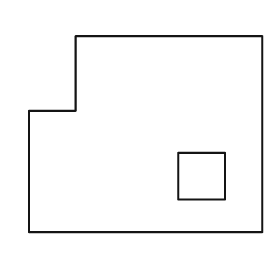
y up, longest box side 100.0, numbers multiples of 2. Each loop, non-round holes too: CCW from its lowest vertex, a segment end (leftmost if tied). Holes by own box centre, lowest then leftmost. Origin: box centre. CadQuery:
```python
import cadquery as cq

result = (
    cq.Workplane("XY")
    .moveTo(-50.0, -42.0)
    .lineTo(50.0, -42.0)
    .lineTo(50.0, 42.0)
    .lineTo(-30.0, 42.0)
    .lineTo(-30.0, 10.0)
    .lineTo(-50.0, 10.0)
    .close()
    .moveTo(14.0, -28.0)
    .lineTo(34.0, -28.0)
    .lineTo(34.0, -8.0)
    .lineTo(14.0, -8.0)
    .close()
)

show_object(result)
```